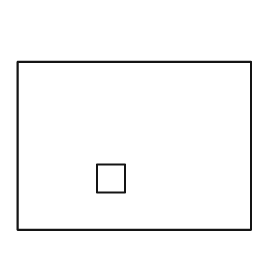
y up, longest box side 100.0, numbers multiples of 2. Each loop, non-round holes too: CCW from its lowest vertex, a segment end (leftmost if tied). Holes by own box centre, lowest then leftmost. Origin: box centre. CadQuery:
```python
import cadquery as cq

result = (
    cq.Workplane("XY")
    .moveTo(-50.0, -36.0)
    .lineTo(50.0, -36.0)
    .lineTo(50.0, 36.0)
    .lineTo(-50.0, 36.0)
    .close()
    .moveTo(-16.0, -20.0)
    .lineTo(-4.0, -20.0)
    .lineTo(-4.0, -8.0)
    .lineTo(-16.0, -8.0)
    .close()
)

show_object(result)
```